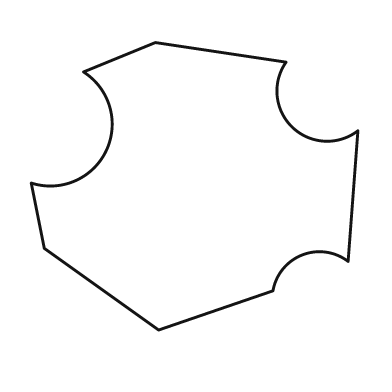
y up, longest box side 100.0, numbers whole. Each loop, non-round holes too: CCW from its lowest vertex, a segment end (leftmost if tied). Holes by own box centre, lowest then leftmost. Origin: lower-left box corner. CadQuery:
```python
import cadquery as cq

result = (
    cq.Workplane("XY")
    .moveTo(39.0, 0.0)
    .lineTo(74.0, 12.0)
    .threePointArc((83.0, 23.0), (97.0, 21.0))
    .lineTo(100.0, 61.0)
    .threePointArc((80.0, 62.0), (78.0, 82.0))
    .lineTo(38.0, 88.0)
    .lineTo(16.0, 79.0)
    .threePointArc((23.0, 55.0), (0.0, 45.0))
    .lineTo(4.0, 25.0)
    .close()
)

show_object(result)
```